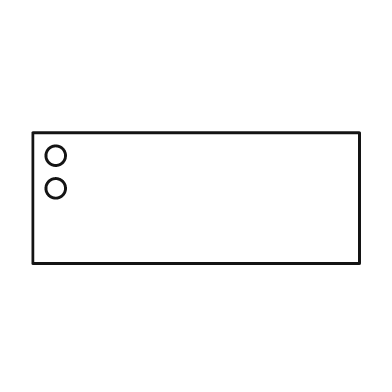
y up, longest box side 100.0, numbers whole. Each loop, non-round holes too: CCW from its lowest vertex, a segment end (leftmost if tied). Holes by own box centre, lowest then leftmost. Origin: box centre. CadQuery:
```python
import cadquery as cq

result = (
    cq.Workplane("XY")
    .moveTo(-50.0, -20.0)
    .lineTo(50.0, -20.0)
    .lineTo(50.0, 20.0)
    .lineTo(-50.0, 20.0)
    .close()
    .moveTo(-43.0, 3.0)
    .circle(3.0)
    .moveTo(-43.0, 13.0)
    .circle(3.0)
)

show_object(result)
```